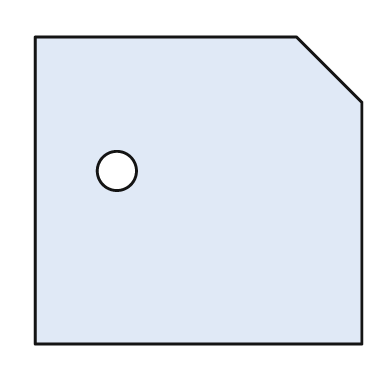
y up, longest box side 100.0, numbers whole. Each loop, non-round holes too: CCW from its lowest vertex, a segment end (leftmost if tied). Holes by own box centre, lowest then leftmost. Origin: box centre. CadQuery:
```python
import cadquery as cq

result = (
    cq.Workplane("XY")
    .moveTo(-50.0, -47.0)
    .lineTo(50.0, -47.0)
    .lineTo(50.0, 27.0)
    .lineTo(30.0, 47.0)
    .lineTo(-50.0, 47.0)
    .close()
    .moveTo(-25.0, 6.0)
    .circle(6.0)
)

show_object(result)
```